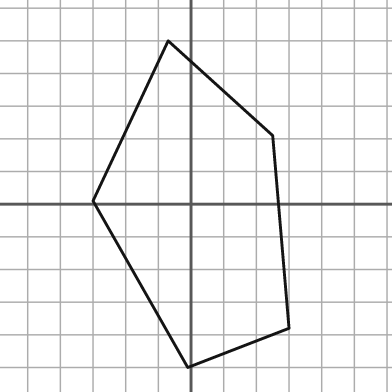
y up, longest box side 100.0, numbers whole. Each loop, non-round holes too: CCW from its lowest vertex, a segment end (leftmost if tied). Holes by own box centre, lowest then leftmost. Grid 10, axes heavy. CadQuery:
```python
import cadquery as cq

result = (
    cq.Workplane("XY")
    .moveTo(-1.0, -50.0)
    .lineTo(30.0, -38.0)
    .lineTo(25.0, 21.0)
    .lineTo(-7.0, 50.0)
    .lineTo(-30.0, 1.0)
    .close()
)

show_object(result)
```